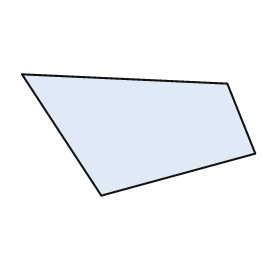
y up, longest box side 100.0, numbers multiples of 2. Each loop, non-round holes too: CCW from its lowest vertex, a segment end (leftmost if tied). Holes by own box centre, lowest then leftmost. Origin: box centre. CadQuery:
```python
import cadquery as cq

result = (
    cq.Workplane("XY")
    .moveTo(-16.0, -26.0)
    .lineTo(50.0, -8.0)
    .lineTo(38.0, 22.0)
    .lineTo(-50.0, 26.0)
    .close()
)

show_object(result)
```